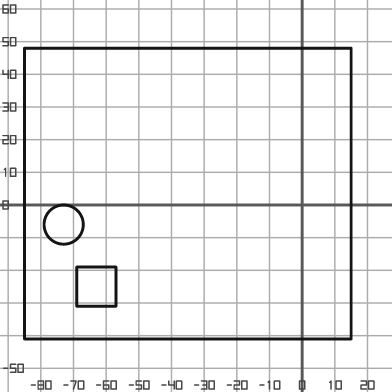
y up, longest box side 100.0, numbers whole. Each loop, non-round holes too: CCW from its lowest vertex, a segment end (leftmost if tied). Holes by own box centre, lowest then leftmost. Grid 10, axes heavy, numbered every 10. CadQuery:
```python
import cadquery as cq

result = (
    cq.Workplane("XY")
    .moveTo(-85.0, -41.0)
    .lineTo(15.0, -41.0)
    .lineTo(15.0, 48.0)
    .lineTo(-85.0, 48.0)
    .close()
    .moveTo(-69.0, -31.0)
    .lineTo(-57.0, -31.0)
    .lineTo(-57.0, -19.0)
    .lineTo(-69.0, -19.0)
    .close()
    .moveTo(-73.0, -6.0)
    .circle(6.0)
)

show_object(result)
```